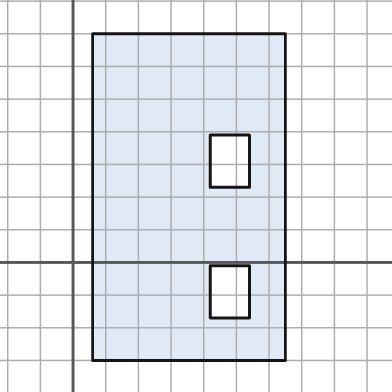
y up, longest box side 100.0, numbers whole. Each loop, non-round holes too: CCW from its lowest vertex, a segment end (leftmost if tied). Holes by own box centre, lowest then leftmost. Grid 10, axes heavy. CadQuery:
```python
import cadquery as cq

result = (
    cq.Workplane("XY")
    .moveTo(6.0, -30.0)
    .lineTo(65.0, -30.0)
    .lineTo(65.0, 70.0)
    .lineTo(6.0, 70.0)
    .close()
    .moveTo(42.0, -17.0)
    .lineTo(54.0, -17.0)
    .lineTo(54.0, -1.0)
    .lineTo(42.0, -1.0)
    .close()
    .moveTo(42.0, 23.0)
    .lineTo(54.0, 23.0)
    .lineTo(54.0, 39.0)
    .lineTo(42.0, 39.0)
    .close()
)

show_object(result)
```